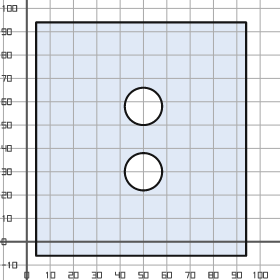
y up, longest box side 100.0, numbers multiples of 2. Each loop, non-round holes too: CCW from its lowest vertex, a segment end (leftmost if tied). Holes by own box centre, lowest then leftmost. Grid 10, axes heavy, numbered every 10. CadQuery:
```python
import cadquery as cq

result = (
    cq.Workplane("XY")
    .moveTo(4.0, -6.0)
    .lineTo(94.0, -6.0)
    .lineTo(94.0, 94.0)
    .lineTo(4.0, 94.0)
    .close()
    .moveTo(50.0, 30.0)
    .circle(8.0)
    .moveTo(50.0, 58.0)
    .circle(8.0)
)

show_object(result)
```